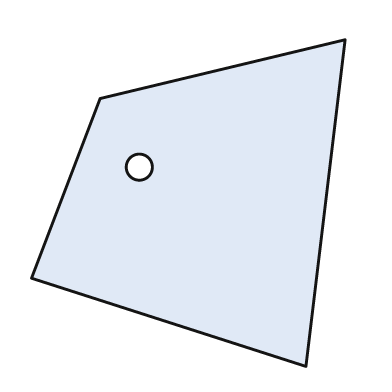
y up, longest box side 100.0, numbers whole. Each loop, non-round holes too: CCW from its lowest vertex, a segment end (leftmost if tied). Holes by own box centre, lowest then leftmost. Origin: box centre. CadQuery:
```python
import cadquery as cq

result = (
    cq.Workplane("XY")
    .moveTo(36.0, -50.0)
    .lineTo(48.0, 50.0)
    .lineTo(-27.0, 32.0)
    .lineTo(-48.0, -23.0)
    .close()
    .moveTo(-15.0, 11.0)
    .circle(4.0)
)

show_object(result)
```